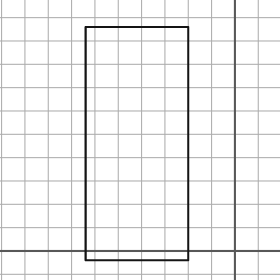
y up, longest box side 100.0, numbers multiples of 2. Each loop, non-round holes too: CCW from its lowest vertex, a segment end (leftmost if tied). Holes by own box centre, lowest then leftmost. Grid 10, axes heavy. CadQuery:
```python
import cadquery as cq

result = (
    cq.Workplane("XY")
    .moveTo(-64.0, -4.0)
    .lineTo(-20.0, -4.0)
    .lineTo(-20.0, 96.0)
    .lineTo(-64.0, 96.0)
    .close()
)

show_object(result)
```